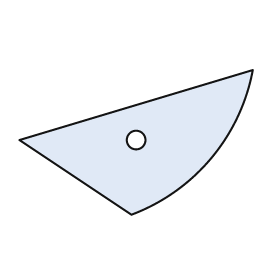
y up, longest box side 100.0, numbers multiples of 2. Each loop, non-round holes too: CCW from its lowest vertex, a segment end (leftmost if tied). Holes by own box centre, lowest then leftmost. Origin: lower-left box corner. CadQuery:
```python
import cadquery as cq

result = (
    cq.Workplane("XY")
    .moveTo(48.0, 0.0)
    .threePointArc((82.0, 24.0), (100.0, 62.0))
    .lineTo(0.0, 32.0)
    .close()
    .moveTo(50.0, 32.0)
    .circle(4.0)
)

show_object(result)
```